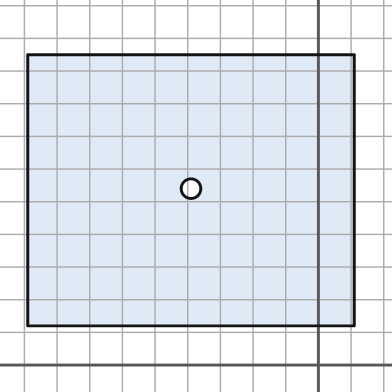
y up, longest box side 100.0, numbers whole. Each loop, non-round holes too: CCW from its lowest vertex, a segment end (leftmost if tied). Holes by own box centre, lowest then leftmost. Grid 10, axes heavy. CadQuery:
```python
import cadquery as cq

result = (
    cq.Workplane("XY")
    .moveTo(-89.0, 12.0)
    .lineTo(11.0, 12.0)
    .lineTo(11.0, 95.0)
    .lineTo(-89.0, 95.0)
    .close()
    .moveTo(-39.0, 54.0)
    .circle(3.0)
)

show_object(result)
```